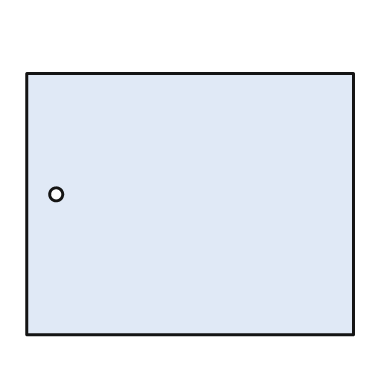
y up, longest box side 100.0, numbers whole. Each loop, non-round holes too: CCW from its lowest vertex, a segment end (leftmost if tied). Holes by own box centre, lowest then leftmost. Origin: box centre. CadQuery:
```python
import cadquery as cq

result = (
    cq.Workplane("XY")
    .moveTo(-50.0, -40.0)
    .lineTo(50.0, -40.0)
    .lineTo(50.0, 40.0)
    .lineTo(-50.0, 40.0)
    .close()
    .moveTo(-41.0, 3.0)
    .circle(2.0)
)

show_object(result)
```